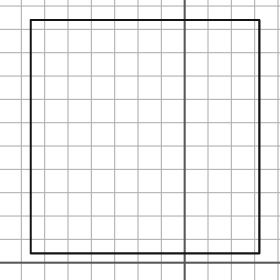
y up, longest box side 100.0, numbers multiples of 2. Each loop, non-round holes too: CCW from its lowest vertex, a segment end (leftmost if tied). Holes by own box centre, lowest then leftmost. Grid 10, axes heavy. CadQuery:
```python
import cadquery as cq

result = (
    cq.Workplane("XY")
    .moveTo(-66.0, 4.0)
    .lineTo(32.0, 4.0)
    .lineTo(32.0, 104.0)
    .lineTo(-66.0, 104.0)
    .close()
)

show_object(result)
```